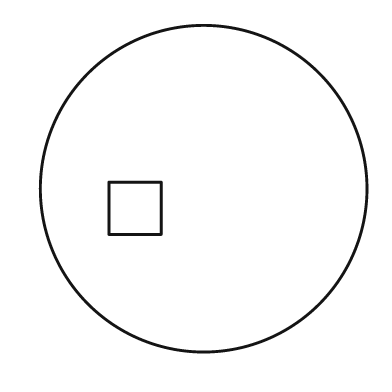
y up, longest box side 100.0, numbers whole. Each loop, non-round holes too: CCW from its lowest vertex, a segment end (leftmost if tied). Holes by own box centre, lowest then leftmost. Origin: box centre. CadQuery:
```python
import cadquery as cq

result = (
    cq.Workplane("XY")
    .moveTo(0.0, 0.0)
    .circle(50.0)
    .moveTo(-29.0, -14.0)
    .lineTo(-13.0, -14.0)
    .lineTo(-13.0, 2.0)
    .lineTo(-29.0, 2.0)
    .close()
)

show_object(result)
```